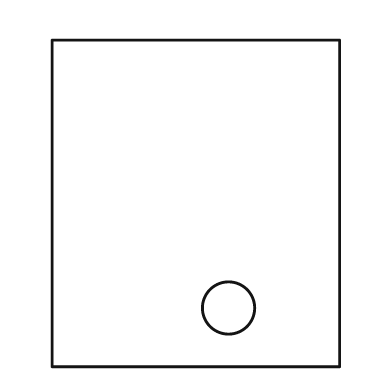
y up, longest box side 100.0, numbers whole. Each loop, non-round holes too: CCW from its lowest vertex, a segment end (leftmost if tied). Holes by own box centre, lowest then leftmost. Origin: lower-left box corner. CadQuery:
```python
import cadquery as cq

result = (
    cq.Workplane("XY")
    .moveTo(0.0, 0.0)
    .lineTo(88.0, 0.0)
    .lineTo(88.0, 100.0)
    .lineTo(0.0, 100.0)
    .close()
    .moveTo(54.0, 18.0)
    .circle(8.0)
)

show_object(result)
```